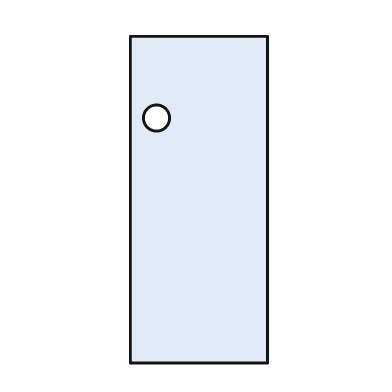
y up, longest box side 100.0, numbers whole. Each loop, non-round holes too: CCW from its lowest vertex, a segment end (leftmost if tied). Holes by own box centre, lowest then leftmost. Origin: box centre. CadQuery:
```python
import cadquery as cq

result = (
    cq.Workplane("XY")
    .moveTo(-21.0, -50.0)
    .lineTo(21.0, -50.0)
    .lineTo(21.0, 50.0)
    .lineTo(-21.0, 50.0)
    .close()
    .moveTo(-13.0, 25.0)
    .circle(4.0)
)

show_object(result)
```